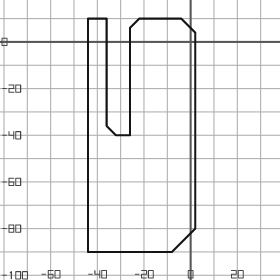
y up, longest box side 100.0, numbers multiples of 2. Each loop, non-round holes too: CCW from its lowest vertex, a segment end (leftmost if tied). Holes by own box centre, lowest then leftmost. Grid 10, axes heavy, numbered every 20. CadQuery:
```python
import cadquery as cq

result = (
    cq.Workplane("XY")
    .moveTo(-44.0, -90.0)
    .lineTo(-8.0, -90.0)
    .lineTo(2.0, -80.0)
    .lineTo(2.0, 4.0)
    .lineTo(-4.0, 10.0)
    .lineTo(-22.0, 10.0)
    .lineTo(-26.0, 6.0)
    .lineTo(-26.0, -40.0)
    .lineTo(-32.0, -40.0)
    .lineTo(-36.0, -36.0)
    .lineTo(-36.0, 10.0)
    .lineTo(-44.0, 10.0)
    .close()
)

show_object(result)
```